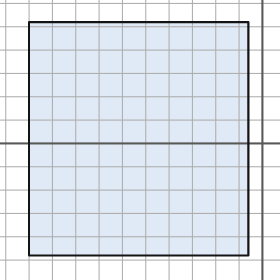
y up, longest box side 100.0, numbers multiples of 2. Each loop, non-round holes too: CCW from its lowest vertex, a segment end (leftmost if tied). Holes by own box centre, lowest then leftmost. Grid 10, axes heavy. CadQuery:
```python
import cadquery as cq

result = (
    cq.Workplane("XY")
    .moveTo(-100.0, -48.0)
    .lineTo(-6.0, -48.0)
    .lineTo(-6.0, 52.0)
    .lineTo(-100.0, 52.0)
    .close()
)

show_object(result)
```